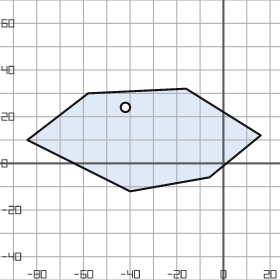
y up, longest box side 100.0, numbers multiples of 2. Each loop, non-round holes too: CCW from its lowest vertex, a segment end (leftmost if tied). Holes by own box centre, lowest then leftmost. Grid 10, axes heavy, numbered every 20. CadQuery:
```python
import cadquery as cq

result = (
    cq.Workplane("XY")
    .moveTo(-40.0, -12.0)
    .lineTo(-6.0, -6.0)
    .lineTo(16.0, 12.0)
    .lineTo(-16.0, 32.0)
    .lineTo(-58.0, 30.0)
    .lineTo(-84.0, 10.0)
    .close()
    .moveTo(-42.0, 24.0)
    .circle(2.0)
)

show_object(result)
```